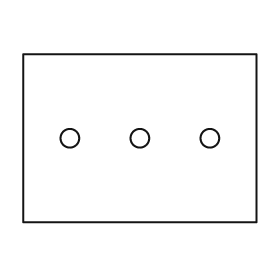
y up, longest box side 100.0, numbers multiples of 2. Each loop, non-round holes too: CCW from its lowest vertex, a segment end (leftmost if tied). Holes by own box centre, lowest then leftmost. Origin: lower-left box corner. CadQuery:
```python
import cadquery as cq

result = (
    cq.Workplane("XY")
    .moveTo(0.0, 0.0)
    .lineTo(100.0, 0.0)
    .lineTo(100.0, 72.0)
    .lineTo(0.0, 72.0)
    .close()
    .moveTo(20.0, 36.0)
    .circle(4.0)
    .moveTo(50.0, 36.0)
    .circle(4.0)
    .moveTo(80.0, 36.0)
    .circle(4.0)
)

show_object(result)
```